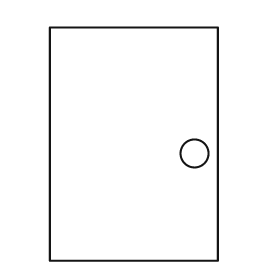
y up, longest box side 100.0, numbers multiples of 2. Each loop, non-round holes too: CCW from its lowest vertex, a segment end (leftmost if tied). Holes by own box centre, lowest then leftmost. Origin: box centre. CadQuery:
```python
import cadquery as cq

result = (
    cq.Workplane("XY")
    .moveTo(-36.0, -50.0)
    .lineTo(36.0, -50.0)
    .lineTo(36.0, 50.0)
    .lineTo(-36.0, 50.0)
    .close()
    .moveTo(26.0, -4.0)
    .circle(6.0)
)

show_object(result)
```